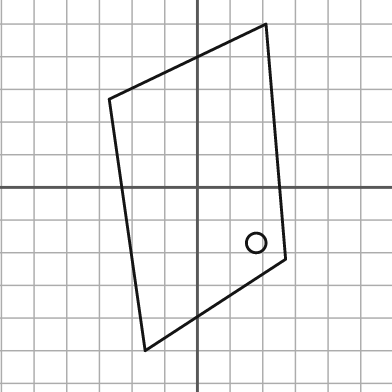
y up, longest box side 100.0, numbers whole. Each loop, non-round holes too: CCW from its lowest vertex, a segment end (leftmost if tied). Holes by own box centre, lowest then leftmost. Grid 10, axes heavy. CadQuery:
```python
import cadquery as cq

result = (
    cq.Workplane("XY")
    .moveTo(-16.0, -50.0)
    .lineTo(27.0, -22.0)
    .lineTo(21.0, 50.0)
    .lineTo(-27.0, 27.0)
    .close()
    .moveTo(18.0, -17.0)
    .circle(3.0)
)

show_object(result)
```